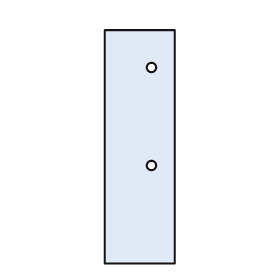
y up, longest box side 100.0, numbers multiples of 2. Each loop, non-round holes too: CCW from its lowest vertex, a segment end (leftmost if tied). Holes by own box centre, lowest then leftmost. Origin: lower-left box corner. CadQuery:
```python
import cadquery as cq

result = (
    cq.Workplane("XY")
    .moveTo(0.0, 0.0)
    .lineTo(30.0, 0.0)
    .lineTo(30.0, 100.0)
    .lineTo(0.0, 100.0)
    .close()
    .moveTo(20.0, 42.0)
    .circle(2.0)
    .moveTo(20.0, 84.0)
    .circle(2.0)
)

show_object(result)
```